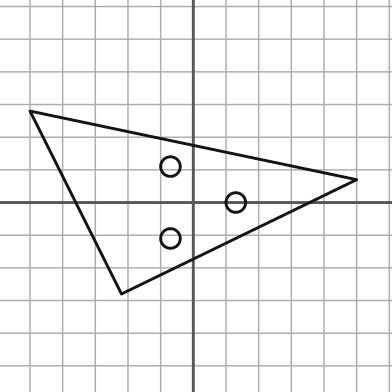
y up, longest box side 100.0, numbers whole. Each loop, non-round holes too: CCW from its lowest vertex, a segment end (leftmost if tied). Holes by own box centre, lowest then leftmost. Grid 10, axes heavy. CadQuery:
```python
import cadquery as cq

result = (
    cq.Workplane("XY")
    .moveTo(-22.0, -28.0)
    .lineTo(50.0, 7.0)
    .lineTo(-50.0, 28.0)
    .close()
    .moveTo(-7.0, -11.0)
    .circle(3.0)
    .moveTo(13.0, 0.0)
    .circle(3.0)
    .moveTo(-7.0, 11.0)
    .circle(3.0)
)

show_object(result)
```